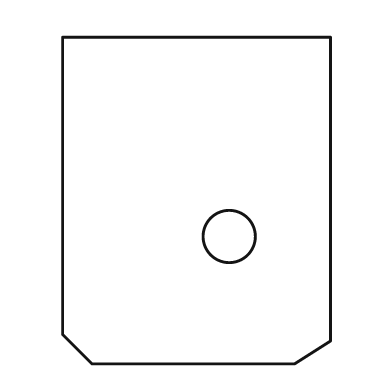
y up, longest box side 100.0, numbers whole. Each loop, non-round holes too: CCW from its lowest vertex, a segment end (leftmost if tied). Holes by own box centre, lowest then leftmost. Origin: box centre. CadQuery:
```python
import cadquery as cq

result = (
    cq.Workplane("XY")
    .moveTo(-32.0, -50.0)
    .lineTo(30.0, -50.0)
    .lineTo(41.0, -43.0)
    .lineTo(41.0, 50.0)
    .lineTo(-41.0, 50.0)
    .lineTo(-41.0, -41.0)
    .close()
    .moveTo(10.0, -11.0)
    .circle(8.0)
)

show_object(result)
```